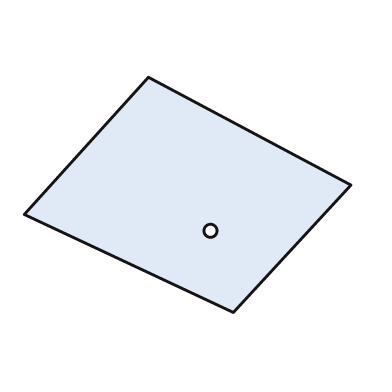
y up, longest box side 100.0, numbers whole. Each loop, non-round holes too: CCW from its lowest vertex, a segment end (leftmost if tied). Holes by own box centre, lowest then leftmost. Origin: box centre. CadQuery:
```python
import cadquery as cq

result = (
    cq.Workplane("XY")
    .moveTo(14.0, -36.0)
    .lineTo(50.0, 3.0)
    .lineTo(-12.0, 36.0)
    .lineTo(-50.0, -6.0)
    .close()
    .moveTo(7.0, -11.0)
    .circle(2.0)
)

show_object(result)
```